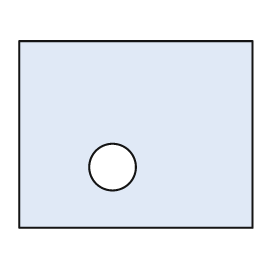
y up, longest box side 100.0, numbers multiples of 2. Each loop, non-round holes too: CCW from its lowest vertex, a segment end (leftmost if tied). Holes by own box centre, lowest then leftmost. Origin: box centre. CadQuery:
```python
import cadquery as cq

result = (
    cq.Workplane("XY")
    .moveTo(-50.0, -40.0)
    .lineTo(50.0, -40.0)
    .lineTo(50.0, 40.0)
    .lineTo(-50.0, 40.0)
    .close()
    .moveTo(-10.0, -14.0)
    .circle(10.0)
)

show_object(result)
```